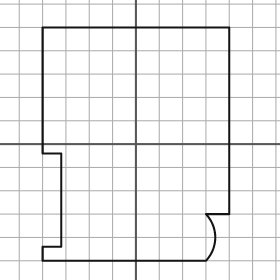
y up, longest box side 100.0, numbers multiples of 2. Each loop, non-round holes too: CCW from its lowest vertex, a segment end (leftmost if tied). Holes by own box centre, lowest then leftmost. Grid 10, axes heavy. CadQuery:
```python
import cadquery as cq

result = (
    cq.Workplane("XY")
    .moveTo(-40.0, -50.0)
    .lineTo(30.0, -50.0)
    .threePointArc((34.0, -40.0), (30.0, -30.0))
    .lineTo(40.0, -30.0)
    .lineTo(40.0, 50.0)
    .lineTo(-40.0, 50.0)
    .lineTo(-40.0, -4.0)
    .lineTo(-32.0, -4.0)
    .lineTo(-32.0, -44.0)
    .lineTo(-40.0, -44.0)
    .close()
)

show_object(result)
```